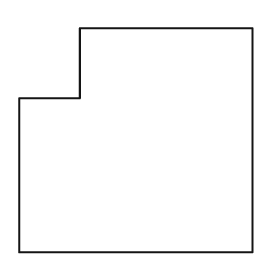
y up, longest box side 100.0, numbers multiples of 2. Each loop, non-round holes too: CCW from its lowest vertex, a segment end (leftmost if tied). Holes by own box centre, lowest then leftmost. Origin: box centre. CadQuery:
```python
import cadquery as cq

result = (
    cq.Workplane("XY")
    .moveTo(-50.0, -48.0)
    .lineTo(50.0, -48.0)
    .lineTo(50.0, 48.0)
    .lineTo(-24.0, 48.0)
    .lineTo(-24.0, 18.0)
    .lineTo(-50.0, 18.0)
    .close()
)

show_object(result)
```